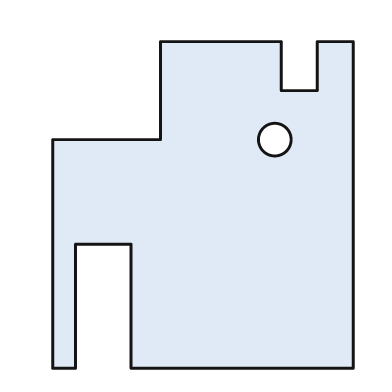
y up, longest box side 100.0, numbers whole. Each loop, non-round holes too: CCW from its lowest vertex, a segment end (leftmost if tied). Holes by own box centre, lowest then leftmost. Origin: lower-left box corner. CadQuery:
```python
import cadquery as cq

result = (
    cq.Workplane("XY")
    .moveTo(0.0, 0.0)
    .lineTo(7.0, 0.0)
    .lineTo(7.0, 38.0)
    .lineTo(24.0, 38.0)
    .lineTo(24.0, 0.0)
    .lineTo(92.0, 0.0)
    .lineTo(92.0, 100.0)
    .lineTo(81.0, 100.0)
    .lineTo(81.0, 85.0)
    .lineTo(70.0, 85.0)
    .lineTo(70.0, 100.0)
    .lineTo(33.0, 100.0)
    .lineTo(33.0, 70.0)
    .lineTo(0.0, 70.0)
    .close()
    .moveTo(68.0, 70.0)
    .circle(5.0)
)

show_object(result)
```